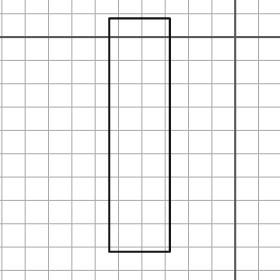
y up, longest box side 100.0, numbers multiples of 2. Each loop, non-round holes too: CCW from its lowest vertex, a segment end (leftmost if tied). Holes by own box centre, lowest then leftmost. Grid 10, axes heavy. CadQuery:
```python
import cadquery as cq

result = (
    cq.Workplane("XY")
    .moveTo(-54.0, -92.0)
    .lineTo(-28.0, -92.0)
    .lineTo(-28.0, 8.0)
    .lineTo(-54.0, 8.0)
    .close()
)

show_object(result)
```